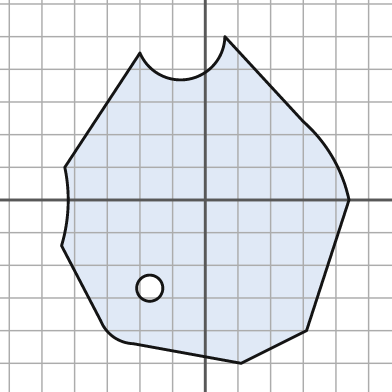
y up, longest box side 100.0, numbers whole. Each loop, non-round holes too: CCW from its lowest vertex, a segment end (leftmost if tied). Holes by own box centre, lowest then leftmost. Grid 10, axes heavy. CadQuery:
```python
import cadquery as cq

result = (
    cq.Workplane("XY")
    .moveTo(11.0, -50.0)
    .lineTo(31.0, -40.0)
    .lineTo(44.0, 0.0)
    .threePointArc((39.0, 13.0), (30.0, 24.0))
    .lineTo(6.0, 50.0)
    .threePointArc((-5.0, 37.0), (-20.0, 45.0))
    .lineTo(-43.0, 10.0)
    .threePointArc((-42.0, -2.0), (-44.0, -14.0))
    .lineTo(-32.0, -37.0)
    .threePointArc((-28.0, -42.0), (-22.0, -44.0))
    .close()
    .moveTo(-17.0, -27.0)
    .circle(4.0)
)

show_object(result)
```